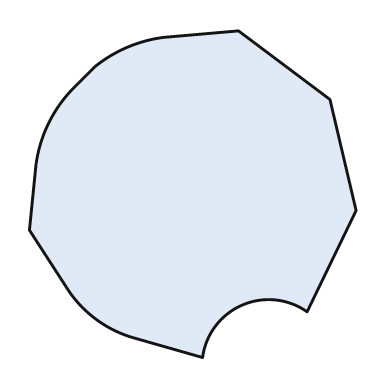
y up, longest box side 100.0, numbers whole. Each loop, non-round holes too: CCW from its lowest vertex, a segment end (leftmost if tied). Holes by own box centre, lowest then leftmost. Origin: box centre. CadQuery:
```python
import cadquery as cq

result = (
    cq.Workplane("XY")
    .moveTo(3.0, -50.0)
    .threePointArc((15.0, -34.0), (35.0, -36.0))
    .lineTo(50.0, -5.0)
    .lineTo(42.0, 29.0)
    .lineTo(14.0, 50.0)
    .lineTo(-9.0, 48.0)
    .threePointArc((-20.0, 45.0), (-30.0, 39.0))
    .lineTo(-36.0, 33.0)
    .threePointArc((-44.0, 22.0), (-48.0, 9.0))
    .lineTo(-50.0, -11.0)
    .lineTo(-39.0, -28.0)
    .threePointArc((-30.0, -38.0), (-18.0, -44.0))
    .close()
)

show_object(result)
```